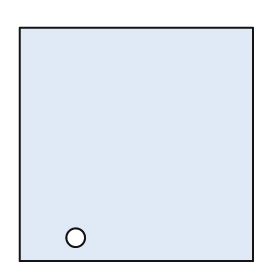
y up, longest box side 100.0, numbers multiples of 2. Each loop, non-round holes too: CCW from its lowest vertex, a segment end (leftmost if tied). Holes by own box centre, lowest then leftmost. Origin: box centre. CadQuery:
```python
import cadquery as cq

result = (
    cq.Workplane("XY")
    .moveTo(-50.0, -50.0)
    .lineTo(50.0, -50.0)
    .lineTo(50.0, 50.0)
    .lineTo(-50.0, 50.0)
    .close()
    .moveTo(-26.0, -40.0)
    .circle(4.0)
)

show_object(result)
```